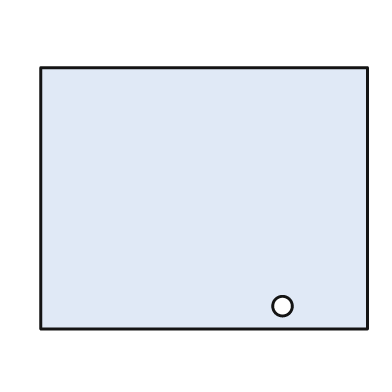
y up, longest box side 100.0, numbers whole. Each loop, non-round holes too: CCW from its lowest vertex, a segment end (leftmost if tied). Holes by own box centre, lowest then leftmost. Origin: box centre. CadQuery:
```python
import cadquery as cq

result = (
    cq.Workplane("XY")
    .moveTo(-50.0, -40.0)
    .lineTo(50.0, -40.0)
    .lineTo(50.0, 40.0)
    .lineTo(-50.0, 40.0)
    .close()
    .moveTo(24.0, -33.0)
    .circle(3.0)
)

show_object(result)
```